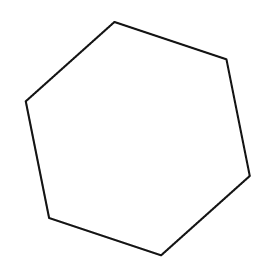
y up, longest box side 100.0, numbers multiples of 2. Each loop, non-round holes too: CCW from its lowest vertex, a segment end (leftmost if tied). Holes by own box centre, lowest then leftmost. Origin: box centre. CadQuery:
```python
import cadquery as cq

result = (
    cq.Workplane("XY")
    .moveTo(10.0, -50.0)
    .lineTo(48.0, -16.0)
    .lineTo(38.0, 34.0)
    .lineTo(-10.0, 50.0)
    .lineTo(-48.0, 16.0)
    .lineTo(-38.0, -34.0)
    .close()
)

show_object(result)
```